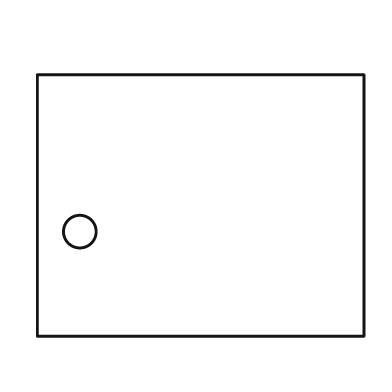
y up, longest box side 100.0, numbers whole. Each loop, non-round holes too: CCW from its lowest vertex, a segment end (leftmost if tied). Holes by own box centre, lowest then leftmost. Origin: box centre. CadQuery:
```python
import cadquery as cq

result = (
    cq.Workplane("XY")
    .moveTo(-50.0, -40.0)
    .lineTo(50.0, -40.0)
    .lineTo(50.0, 40.0)
    .lineTo(-50.0, 40.0)
    .close()
    .moveTo(-37.0, -8.0)
    .circle(5.0)
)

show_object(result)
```